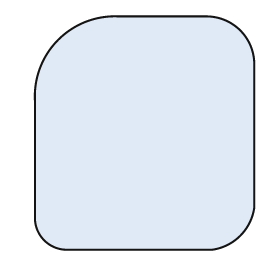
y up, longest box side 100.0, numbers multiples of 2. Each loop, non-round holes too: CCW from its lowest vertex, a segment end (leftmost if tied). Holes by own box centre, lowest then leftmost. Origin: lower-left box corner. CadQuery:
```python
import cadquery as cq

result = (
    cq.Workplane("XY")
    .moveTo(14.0, 0.0)
    .lineTo(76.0, 0.0)
    .threePointArc((88.0, 6.0), (94.0, 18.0))
    .lineTo(94.0, 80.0)
    .threePointArc((88.0, 94.0), (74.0, 100.0))
    .lineTo(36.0, 100.0)
    .threePointArc((10.0, 90.0), (0.0, 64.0))
    .lineTo(0.0, 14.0)
    .threePointArc((4.0, 4.0), (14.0, 0.0))
    .close()
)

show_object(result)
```